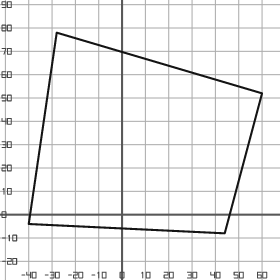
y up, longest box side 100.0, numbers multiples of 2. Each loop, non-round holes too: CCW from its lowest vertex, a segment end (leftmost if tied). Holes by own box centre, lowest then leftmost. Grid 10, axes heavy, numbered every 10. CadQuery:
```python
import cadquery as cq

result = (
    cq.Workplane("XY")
    .moveTo(44.0, -8.0)
    .lineTo(60.0, 52.0)
    .lineTo(-28.0, 78.0)
    .lineTo(-40.0, -4.0)
    .close()
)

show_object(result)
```